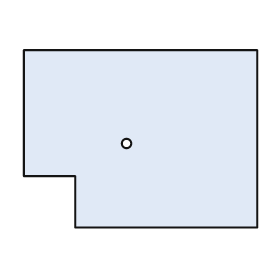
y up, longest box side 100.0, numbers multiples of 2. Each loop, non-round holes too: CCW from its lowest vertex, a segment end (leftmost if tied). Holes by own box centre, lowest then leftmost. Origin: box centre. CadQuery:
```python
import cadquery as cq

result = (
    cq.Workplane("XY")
    .moveTo(-28.0, -38.0)
    .lineTo(50.0, -38.0)
    .lineTo(50.0, 38.0)
    .lineTo(-50.0, 38.0)
    .lineTo(-50.0, -16.0)
    .lineTo(-28.0, -16.0)
    .close()
    .moveTo(-6.0, -2.0)
    .circle(2.0)
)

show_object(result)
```